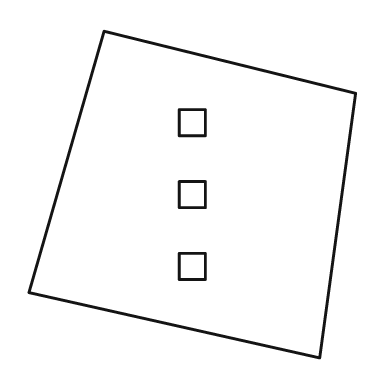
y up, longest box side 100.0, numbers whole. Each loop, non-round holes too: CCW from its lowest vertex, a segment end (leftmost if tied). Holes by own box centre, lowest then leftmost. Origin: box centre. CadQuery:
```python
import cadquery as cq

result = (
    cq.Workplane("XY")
    .moveTo(39.0, -50.0)
    .lineTo(50.0, 31.0)
    .lineTo(-27.0, 50.0)
    .lineTo(-50.0, -30.0)
    .close()
    .moveTo(-4.0, -26.0)
    .lineTo(4.0, -26.0)
    .lineTo(4.0, -18.0)
    .lineTo(-4.0, -18.0)
    .close()
    .moveTo(-4.0, -4.0)
    .lineTo(4.0, -4.0)
    .lineTo(4.0, 4.0)
    .lineTo(-4.0, 4.0)
    .close()
    .moveTo(-4.0, 18.0)
    .lineTo(4.0, 18.0)
    .lineTo(4.0, 26.0)
    .lineTo(-4.0, 26.0)
    .close()
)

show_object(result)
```